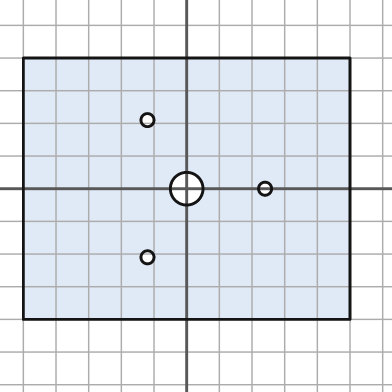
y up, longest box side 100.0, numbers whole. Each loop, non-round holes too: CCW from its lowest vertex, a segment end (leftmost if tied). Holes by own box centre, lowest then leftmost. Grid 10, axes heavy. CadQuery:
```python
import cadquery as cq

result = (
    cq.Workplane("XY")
    .moveTo(-50.0, -40.0)
    .lineTo(50.0, -40.0)
    .lineTo(50.0, 40.0)
    .lineTo(-50.0, 40.0)
    .close()
    .moveTo(-12.0, -21.0)
    .circle(2.0)
    .moveTo(0.0, 0.0)
    .circle(5.0)
    .moveTo(24.0, 0.0)
    .circle(2.0)
    .moveTo(-12.0, 21.0)
    .circle(2.0)
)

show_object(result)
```